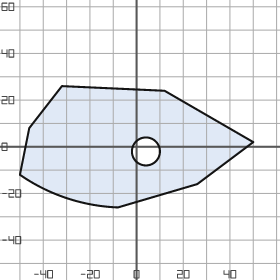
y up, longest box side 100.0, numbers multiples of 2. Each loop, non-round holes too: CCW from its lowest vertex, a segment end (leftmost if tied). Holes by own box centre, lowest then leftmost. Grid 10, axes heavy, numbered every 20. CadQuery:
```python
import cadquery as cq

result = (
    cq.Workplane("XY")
    .moveTo(-8.0, -26.0)
    .lineTo(26.0, -16.0)
    .lineTo(50.0, 2.0)
    .lineTo(12.0, 24.0)
    .lineTo(-32.0, 26.0)
    .lineTo(-46.0, 8.0)
    .lineTo(-50.0, -12.0)
    .threePointArc((-30.0, -22.0), (-8.0, -26.0))
    .close()
    .moveTo(4.0, -2.0)
    .circle(6.0)
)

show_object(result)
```